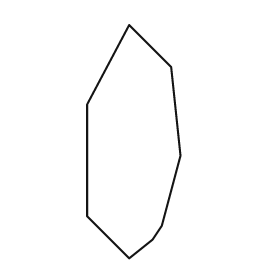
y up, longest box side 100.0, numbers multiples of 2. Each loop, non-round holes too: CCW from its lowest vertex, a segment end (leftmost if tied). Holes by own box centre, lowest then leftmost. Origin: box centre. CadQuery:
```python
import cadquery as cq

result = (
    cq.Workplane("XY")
    .moveTo(-2.0, -50.0)
    .lineTo(8.0, -42.0)
    .lineTo(12.0, -36.0)
    .lineTo(20.0, -6.0)
    .lineTo(16.0, 32.0)
    .lineTo(-2.0, 50.0)
    .lineTo(-20.0, 16.0)
    .lineTo(-20.0, -32.0)
    .close()
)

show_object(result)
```